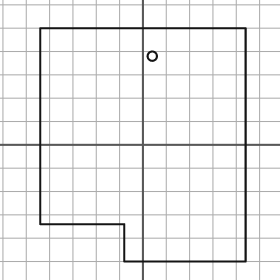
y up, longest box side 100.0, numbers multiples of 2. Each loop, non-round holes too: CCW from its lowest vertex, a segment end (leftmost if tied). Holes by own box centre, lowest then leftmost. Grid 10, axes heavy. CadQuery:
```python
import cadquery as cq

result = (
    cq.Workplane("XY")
    .moveTo(-8.0, -50.0)
    .lineTo(44.0, -50.0)
    .lineTo(44.0, 50.0)
    .lineTo(-44.0, 50.0)
    .lineTo(-44.0, -34.0)
    .lineTo(-8.0, -34.0)
    .close()
    .moveTo(4.0, 38.0)
    .circle(2.0)
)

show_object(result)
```